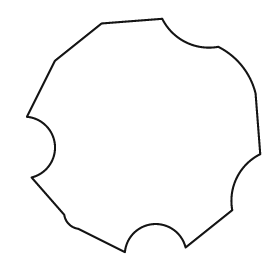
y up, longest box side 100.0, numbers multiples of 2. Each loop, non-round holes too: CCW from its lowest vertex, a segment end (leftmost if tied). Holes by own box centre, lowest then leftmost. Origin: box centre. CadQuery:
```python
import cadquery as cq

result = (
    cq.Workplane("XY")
    .moveTo(-8.0, -50.0)
    .threePointArc((4.0, -38.0), (18.0, -48.0))
    .lineTo(38.0, -32.0)
    .threePointArc((40.0, -18.0), (50.0, -8.0))
    .lineTo(48.0, 18.0)
    .threePointArc((42.0, 30.0), (32.0, 38.0))
    .threePointArc((18.0, 40.0), (8.0, 50.0))
    .lineTo(-18.0, 48.0)
    .lineTo(-38.0, 32.0)
    .lineTo(-50.0, 8.0)
    .threePointArc((-38.0, -4.0), (-48.0, -18.0))
    .lineTo(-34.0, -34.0)
    .threePointArc((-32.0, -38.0), (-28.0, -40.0))
    .close()
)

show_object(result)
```